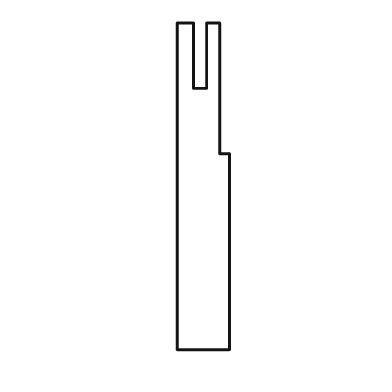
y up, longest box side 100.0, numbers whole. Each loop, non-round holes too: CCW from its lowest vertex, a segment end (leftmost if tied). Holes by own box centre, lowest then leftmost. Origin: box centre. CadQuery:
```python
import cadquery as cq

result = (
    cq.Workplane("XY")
    .moveTo(-8.0, -50.0)
    .lineTo(8.0, -50.0)
    .lineTo(8.0, 10.0)
    .lineTo(5.0, 10.0)
    .lineTo(5.0, 50.0)
    .lineTo(1.0, 50.0)
    .lineTo(1.0, 30.0)
    .lineTo(-3.0, 30.0)
    .lineTo(-3.0, 50.0)
    .lineTo(-8.0, 50.0)
    .close()
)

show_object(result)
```